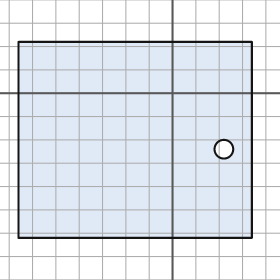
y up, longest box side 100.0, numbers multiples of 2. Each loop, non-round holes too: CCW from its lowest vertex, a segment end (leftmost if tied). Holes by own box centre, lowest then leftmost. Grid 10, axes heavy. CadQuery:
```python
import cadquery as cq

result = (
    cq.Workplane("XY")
    .moveTo(-66.0, -62.0)
    .lineTo(34.0, -62.0)
    .lineTo(34.0, 22.0)
    .lineTo(-66.0, 22.0)
    .close()
    .moveTo(22.0, -24.0)
    .circle(4.0)
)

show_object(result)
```